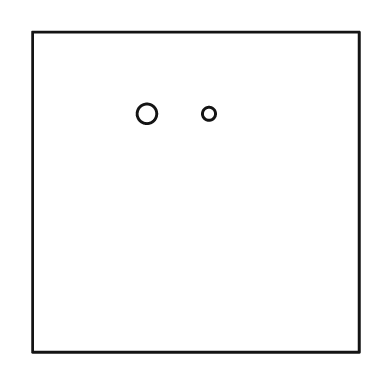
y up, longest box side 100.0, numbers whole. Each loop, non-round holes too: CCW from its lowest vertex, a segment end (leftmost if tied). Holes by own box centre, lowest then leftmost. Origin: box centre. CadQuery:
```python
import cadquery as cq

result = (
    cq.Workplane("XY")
    .moveTo(-50.0, -49.0)
    .lineTo(50.0, -49.0)
    .lineTo(50.0, 49.0)
    .lineTo(-50.0, 49.0)
    .close()
    .moveTo(-15.0, 24.0)
    .circle(3.0)
    .moveTo(4.0, 24.0)
    .circle(2.0)
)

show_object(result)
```